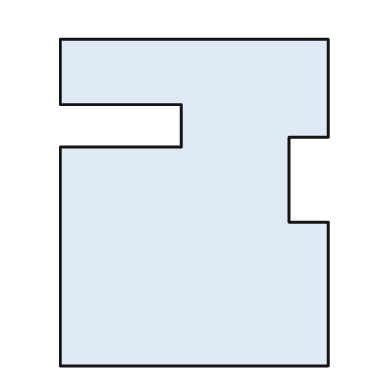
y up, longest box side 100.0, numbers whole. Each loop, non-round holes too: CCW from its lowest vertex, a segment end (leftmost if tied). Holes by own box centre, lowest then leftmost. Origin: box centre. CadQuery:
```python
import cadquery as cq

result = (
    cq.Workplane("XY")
    .moveTo(-41.0, -50.0)
    .lineTo(41.0, -50.0)
    .lineTo(41.0, -6.0)
    .lineTo(29.0, -6.0)
    .lineTo(29.0, 20.0)
    .lineTo(41.0, 20.0)
    .lineTo(41.0, 50.0)
    .lineTo(-41.0, 50.0)
    .lineTo(-41.0, 30.0)
    .lineTo(-4.0, 30.0)
    .lineTo(-4.0, 17.0)
    .lineTo(-41.0, 17.0)
    .close()
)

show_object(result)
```